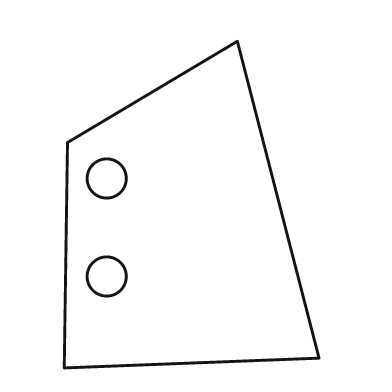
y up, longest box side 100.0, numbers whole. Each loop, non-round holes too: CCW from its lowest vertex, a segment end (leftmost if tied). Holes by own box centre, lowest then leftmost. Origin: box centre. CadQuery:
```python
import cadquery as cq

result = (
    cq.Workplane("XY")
    .moveTo(-39.0, -50.0)
    .lineTo(39.0, -47.0)
    .lineTo(14.0, 50.0)
    .lineTo(-38.0, 19.0)
    .close()
    .moveTo(-26.0, -22.0)
    .circle(6.0)
    .moveTo(-26.0, 8.0)
    .circle(6.0)
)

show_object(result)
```